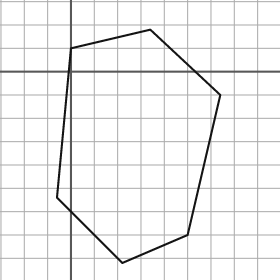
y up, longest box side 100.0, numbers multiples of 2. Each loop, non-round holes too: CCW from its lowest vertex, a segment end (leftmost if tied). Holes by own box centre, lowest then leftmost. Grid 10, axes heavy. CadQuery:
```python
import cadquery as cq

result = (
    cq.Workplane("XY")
    .moveTo(22.0, -82.0)
    .lineTo(50.0, -70.0)
    .lineTo(64.0, -10.0)
    .lineTo(34.0, 18.0)
    .lineTo(0.0, 10.0)
    .lineTo(-6.0, -54.0)
    .close()
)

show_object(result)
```